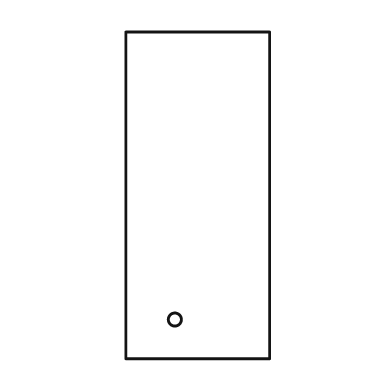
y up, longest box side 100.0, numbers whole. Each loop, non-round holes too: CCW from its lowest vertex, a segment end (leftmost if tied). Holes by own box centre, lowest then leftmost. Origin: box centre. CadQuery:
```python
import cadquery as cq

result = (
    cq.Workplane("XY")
    .moveTo(-22.0, -50.0)
    .lineTo(22.0, -50.0)
    .lineTo(22.0, 50.0)
    .lineTo(-22.0, 50.0)
    .close()
    .moveTo(-7.0, -38.0)
    .circle(2.0)
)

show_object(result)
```